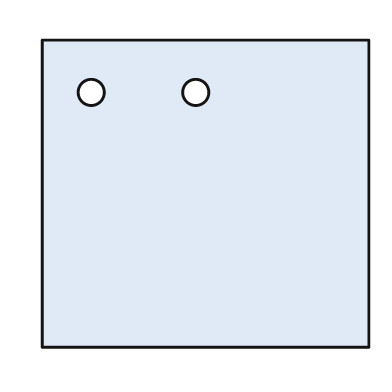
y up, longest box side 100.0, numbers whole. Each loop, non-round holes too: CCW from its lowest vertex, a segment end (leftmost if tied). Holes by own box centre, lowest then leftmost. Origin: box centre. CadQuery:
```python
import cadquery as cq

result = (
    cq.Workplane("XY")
    .moveTo(-50.0, -47.0)
    .lineTo(50.0, -47.0)
    .lineTo(50.0, 47.0)
    .lineTo(-50.0, 47.0)
    .close()
    .moveTo(-35.0, 31.0)
    .circle(4.0)
    .moveTo(-3.0, 31.0)
    .circle(4.0)
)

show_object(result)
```